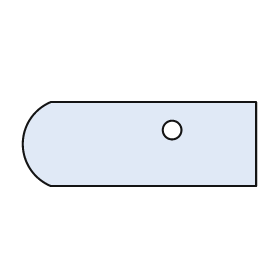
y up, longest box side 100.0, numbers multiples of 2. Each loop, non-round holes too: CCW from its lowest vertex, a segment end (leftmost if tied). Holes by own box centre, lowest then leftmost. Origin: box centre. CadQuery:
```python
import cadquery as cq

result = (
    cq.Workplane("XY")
    .moveTo(-38.0, -18.0)
    .lineTo(50.0, -18.0)
    .lineTo(50.0, 18.0)
    .lineTo(-38.0, 18.0)
    .threePointArc((-50.0, 0.0), (-38.0, -18.0))
    .close()
    .moveTo(14.0, 6.0)
    .circle(4.0)
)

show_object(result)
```